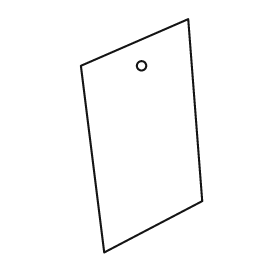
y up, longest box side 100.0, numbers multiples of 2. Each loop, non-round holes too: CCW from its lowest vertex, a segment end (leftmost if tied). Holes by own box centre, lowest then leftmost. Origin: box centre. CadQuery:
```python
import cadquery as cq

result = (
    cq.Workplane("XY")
    .moveTo(-16.0, -50.0)
    .lineTo(26.0, -28.0)
    .lineTo(20.0, 50.0)
    .lineTo(-26.0, 30.0)
    .close()
    .moveTo(0.0, 30.0)
    .circle(2.0)
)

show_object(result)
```